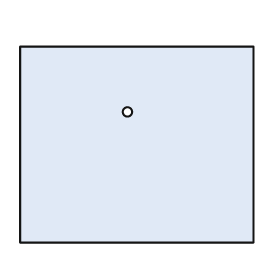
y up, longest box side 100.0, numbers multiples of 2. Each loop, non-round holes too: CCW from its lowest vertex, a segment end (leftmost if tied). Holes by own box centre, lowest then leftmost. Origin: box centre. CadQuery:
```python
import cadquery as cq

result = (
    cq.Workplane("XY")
    .moveTo(-50.0, -42.0)
    .lineTo(50.0, -42.0)
    .lineTo(50.0, 42.0)
    .lineTo(-50.0, 42.0)
    .close()
    .moveTo(-4.0, 14.0)
    .circle(2.0)
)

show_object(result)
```